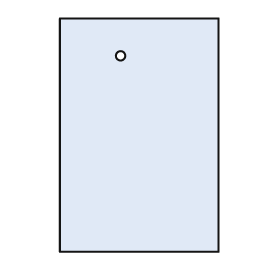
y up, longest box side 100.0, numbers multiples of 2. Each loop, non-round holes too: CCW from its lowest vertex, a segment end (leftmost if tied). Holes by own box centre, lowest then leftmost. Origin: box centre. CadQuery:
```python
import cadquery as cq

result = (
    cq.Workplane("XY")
    .moveTo(-34.0, -50.0)
    .lineTo(34.0, -50.0)
    .lineTo(34.0, 50.0)
    .lineTo(-34.0, 50.0)
    .close()
    .moveTo(-8.0, 34.0)
    .circle(2.0)
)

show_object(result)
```